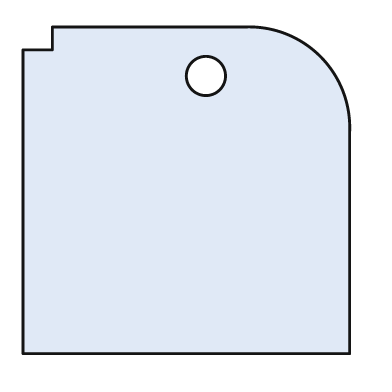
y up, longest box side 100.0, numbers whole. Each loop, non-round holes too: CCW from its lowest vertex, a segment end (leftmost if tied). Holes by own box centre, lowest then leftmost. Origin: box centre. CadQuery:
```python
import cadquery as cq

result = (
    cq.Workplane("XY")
    .moveTo(-50.0, -50.0)
    .lineTo(50.0, -50.0)
    .lineTo(50.0, 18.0)
    .threePointArc((41.0, 41.0), (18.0, 50.0))
    .lineTo(-41.0, 50.0)
    .lineTo(-41.0, 43.0)
    .lineTo(-50.0, 43.0)
    .close()
    .moveTo(6.0, 35.0)
    .circle(6.0)
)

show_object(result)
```